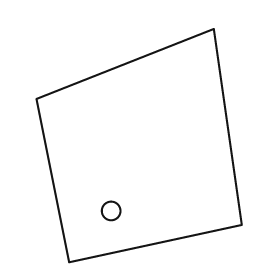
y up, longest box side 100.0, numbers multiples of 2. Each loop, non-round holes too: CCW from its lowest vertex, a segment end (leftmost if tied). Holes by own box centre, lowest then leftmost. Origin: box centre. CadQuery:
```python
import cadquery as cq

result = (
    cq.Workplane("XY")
    .moveTo(-30.0, -50.0)
    .lineTo(44.0, -34.0)
    .lineTo(32.0, 50.0)
    .lineTo(-44.0, 20.0)
    .close()
    .moveTo(-12.0, -28.0)
    .circle(4.0)
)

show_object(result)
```